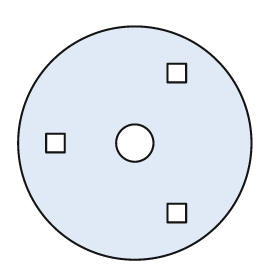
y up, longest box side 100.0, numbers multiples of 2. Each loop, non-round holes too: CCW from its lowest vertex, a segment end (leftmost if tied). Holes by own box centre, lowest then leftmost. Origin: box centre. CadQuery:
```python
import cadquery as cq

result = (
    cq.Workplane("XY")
    .moveTo(0.0, 0.0)
    .circle(50.0)
    .moveTo(14.0, -34.0)
    .lineTo(22.0, -34.0)
    .lineTo(22.0, -26.0)
    .lineTo(14.0, -26.0)
    .close()
    .moveTo(-38.0, -4.0)
    .lineTo(-30.0, -4.0)
    .lineTo(-30.0, 4.0)
    .lineTo(-38.0, 4.0)
    .close()
    .moveTo(0.0, 0.0)
    .circle(8.0)
    .moveTo(14.0, 26.0)
    .lineTo(22.0, 26.0)
    .lineTo(22.0, 34.0)
    .lineTo(14.0, 34.0)
    .close()
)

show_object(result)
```